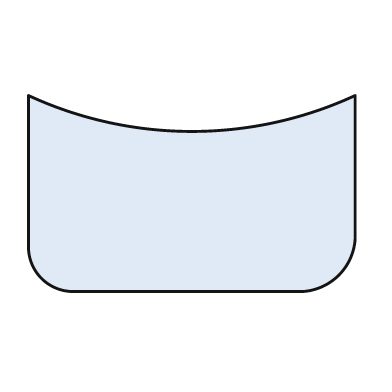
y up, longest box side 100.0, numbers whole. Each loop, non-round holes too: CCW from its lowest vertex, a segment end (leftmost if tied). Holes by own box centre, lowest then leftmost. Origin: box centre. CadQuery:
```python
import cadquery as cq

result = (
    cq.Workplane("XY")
    .moveTo(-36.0, -30.0)
    .lineTo(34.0, -30.0)
    .threePointArc((45.0, -25.0), (50.0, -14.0))
    .lineTo(50.0, 30.0)
    .threePointArc((0.0, 19.0), (-50.0, 30.0))
    .lineTo(-50.0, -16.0)
    .threePointArc((-46.0, -26.0), (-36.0, -30.0))
    .close()
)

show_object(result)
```